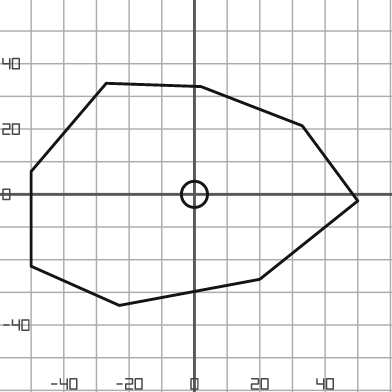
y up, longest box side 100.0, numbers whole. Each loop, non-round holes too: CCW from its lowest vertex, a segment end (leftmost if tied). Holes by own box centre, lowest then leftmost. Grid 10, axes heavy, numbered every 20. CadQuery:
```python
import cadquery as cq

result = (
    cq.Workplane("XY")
    .moveTo(-23.0, -34.0)
    .lineTo(20.0, -26.0)
    .lineTo(50.0, -2.0)
    .lineTo(33.0, 21.0)
    .lineTo(2.0, 33.0)
    .lineTo(-27.0, 34.0)
    .lineTo(-50.0, 7.0)
    .lineTo(-50.0, -22.0)
    .close()
    .moveTo(0.0, 0.0)
    .circle(4.0)
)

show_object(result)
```